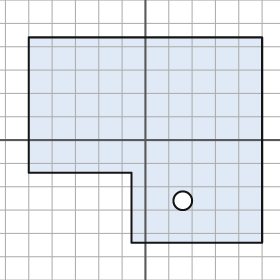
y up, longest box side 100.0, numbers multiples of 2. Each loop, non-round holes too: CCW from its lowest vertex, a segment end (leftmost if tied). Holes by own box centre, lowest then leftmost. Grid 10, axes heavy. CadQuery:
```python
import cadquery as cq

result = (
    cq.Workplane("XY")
    .moveTo(-6.0, -44.0)
    .lineTo(50.0, -44.0)
    .lineTo(50.0, 44.0)
    .lineTo(-50.0, 44.0)
    .lineTo(-50.0, -14.0)
    .lineTo(-6.0, -14.0)
    .close()
    .moveTo(16.0, -26.0)
    .circle(4.0)
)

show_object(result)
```